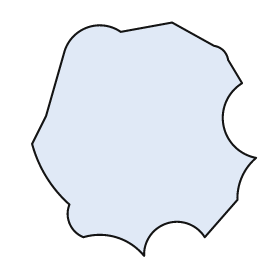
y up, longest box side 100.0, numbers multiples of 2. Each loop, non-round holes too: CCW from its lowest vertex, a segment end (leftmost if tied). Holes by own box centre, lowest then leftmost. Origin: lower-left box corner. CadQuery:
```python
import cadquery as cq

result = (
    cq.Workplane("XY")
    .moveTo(48.0, 0.0)
    .threePointArc((58.0, 14.0), (74.0, 8.0))
    .lineTo(88.0, 24.0)
    .threePointArc((90.0, 34.0), (96.0, 42.0))
    .threePointArc((82.0, 56.0), (90.0, 74.0))
    .lineTo(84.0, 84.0)
    .threePointArc((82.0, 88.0), (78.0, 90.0))
    .lineTo(60.0, 100.0)
    .lineTo(38.0, 96.0)
    .threePointArc((24.0, 98.0), (14.0, 88.0))
    .lineTo(6.0, 60.0)
    .lineTo(0.0, 48.0)
    .threePointArc((6.0, 34.0), (16.0, 22.0))
    .threePointArc((16.0, 14.0), (22.0, 8.0))
    .threePointArc((36.0, 8.0), (48.0, 0.0))
    .close()
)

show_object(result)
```